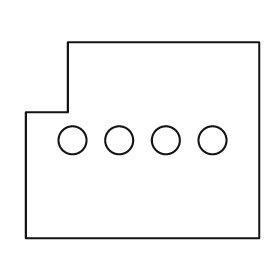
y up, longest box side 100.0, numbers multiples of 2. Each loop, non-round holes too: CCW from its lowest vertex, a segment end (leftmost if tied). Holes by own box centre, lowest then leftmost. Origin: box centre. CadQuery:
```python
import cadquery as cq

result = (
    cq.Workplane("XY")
    .moveTo(-50.0, -42.0)
    .lineTo(50.0, -42.0)
    .lineTo(50.0, 42.0)
    .lineTo(-32.0, 42.0)
    .lineTo(-32.0, 12.0)
    .lineTo(-50.0, 12.0)
    .close()
    .moveTo(-30.0, 0.0)
    .circle(6.0)
    .moveTo(-10.0, 0.0)
    .circle(6.0)
    .moveTo(10.0, 0.0)
    .circle(6.0)
    .moveTo(30.0, 0.0)
    .circle(6.0)
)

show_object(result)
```